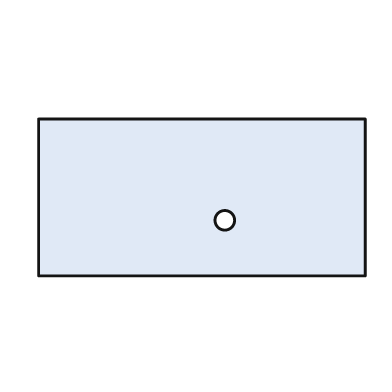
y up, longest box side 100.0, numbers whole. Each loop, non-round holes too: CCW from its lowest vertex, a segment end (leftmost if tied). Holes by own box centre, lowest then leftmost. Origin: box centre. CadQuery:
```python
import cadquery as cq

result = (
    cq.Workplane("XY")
    .moveTo(-50.0, -24.0)
    .lineTo(50.0, -24.0)
    .lineTo(50.0, 24.0)
    .lineTo(-50.0, 24.0)
    .close()
    .moveTo(7.0, -7.0)
    .circle(3.0)
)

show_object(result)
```